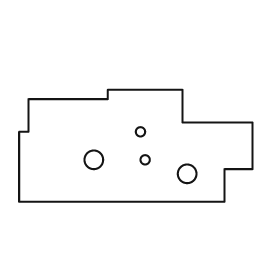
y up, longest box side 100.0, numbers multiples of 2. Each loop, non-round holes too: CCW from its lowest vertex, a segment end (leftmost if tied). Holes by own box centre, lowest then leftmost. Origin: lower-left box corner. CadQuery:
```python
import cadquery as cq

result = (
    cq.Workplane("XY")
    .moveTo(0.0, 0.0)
    .lineTo(88.0, 0.0)
    .lineTo(88.0, 14.0)
    .lineTo(100.0, 14.0)
    .lineTo(100.0, 34.0)
    .lineTo(70.0, 34.0)
    .lineTo(70.0, 48.0)
    .lineTo(38.0, 48.0)
    .lineTo(38.0, 44.0)
    .lineTo(4.0, 44.0)
    .lineTo(4.0, 30.0)
    .lineTo(0.0, 30.0)
    .close()
    .moveTo(72.0, 12.0)
    .circle(4.0)
    .moveTo(32.0, 18.0)
    .circle(4.0)
    .moveTo(54.0, 18.0)
    .circle(2.0)
    .moveTo(52.0, 30.0)
    .circle(2.0)
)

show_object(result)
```